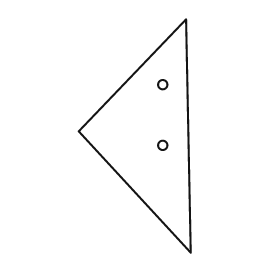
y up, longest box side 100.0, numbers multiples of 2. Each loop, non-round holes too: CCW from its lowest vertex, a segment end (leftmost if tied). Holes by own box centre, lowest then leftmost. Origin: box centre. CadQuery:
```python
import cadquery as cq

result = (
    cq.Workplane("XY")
    .moveTo(24.0, -50.0)
    .lineTo(22.0, 50.0)
    .lineTo(-24.0, 2.0)
    .close()
    .moveTo(12.0, -4.0)
    .circle(2.0)
    .moveTo(12.0, 22.0)
    .circle(2.0)
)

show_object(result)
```